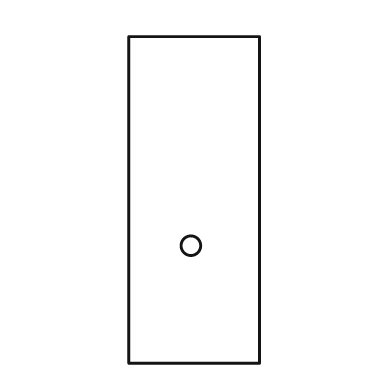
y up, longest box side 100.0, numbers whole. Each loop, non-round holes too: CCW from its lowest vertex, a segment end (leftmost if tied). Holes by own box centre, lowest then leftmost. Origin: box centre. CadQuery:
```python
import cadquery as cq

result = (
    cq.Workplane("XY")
    .moveTo(-20.0, -50.0)
    .lineTo(20.0, -50.0)
    .lineTo(20.0, 50.0)
    .lineTo(-20.0, 50.0)
    .close()
    .moveTo(-1.0, -14.0)
    .circle(3.0)
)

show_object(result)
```